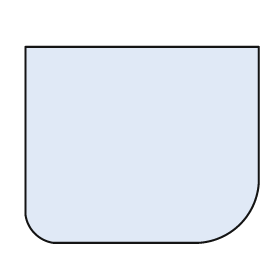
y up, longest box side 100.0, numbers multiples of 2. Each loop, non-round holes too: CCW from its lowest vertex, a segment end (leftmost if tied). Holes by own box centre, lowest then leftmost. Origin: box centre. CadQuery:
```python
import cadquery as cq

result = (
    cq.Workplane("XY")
    .moveTo(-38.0, -42.0)
    .lineTo(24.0, -42.0)
    .threePointArc((42.0, -34.0), (50.0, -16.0))
    .lineTo(50.0, 42.0)
    .lineTo(-50.0, 42.0)
    .lineTo(-50.0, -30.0)
    .threePointArc((-46.0, -38.0), (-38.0, -42.0))
    .close()
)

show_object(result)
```